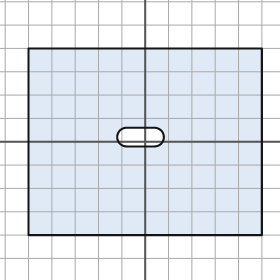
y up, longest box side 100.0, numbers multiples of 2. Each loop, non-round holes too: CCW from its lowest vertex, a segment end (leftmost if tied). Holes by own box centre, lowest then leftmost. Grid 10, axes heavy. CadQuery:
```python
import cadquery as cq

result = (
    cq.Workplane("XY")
    .moveTo(-50.0, -40.0)
    .lineTo(50.0, -40.0)
    .lineTo(50.0, 40.0)
    .lineTo(-50.0, 40.0)
    .close()
    .moveTo(-8.0, -2.0)
    .lineTo(4.0, -2.0)
    .threePointArc((8.0, 2.0), (4.0, 6.0))
    .lineTo(-8.0, 6.0)
    .threePointArc((-12.0, 2.0), (-8.0, -2.0))
    .close()
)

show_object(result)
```